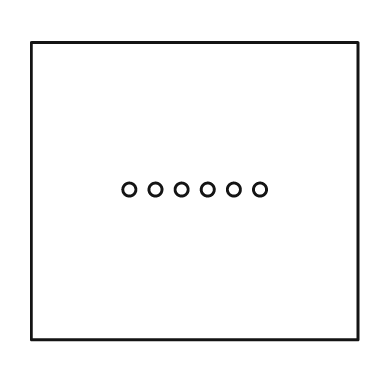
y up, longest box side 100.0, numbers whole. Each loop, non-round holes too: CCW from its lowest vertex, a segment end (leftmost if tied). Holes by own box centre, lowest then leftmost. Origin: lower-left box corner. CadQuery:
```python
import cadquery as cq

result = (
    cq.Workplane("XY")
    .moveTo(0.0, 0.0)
    .lineTo(100.0, 0.0)
    .lineTo(100.0, 91.0)
    .lineTo(0.0, 91.0)
    .close()
    .moveTo(30.0, 46.0)
    .circle(2.0)
    .moveTo(38.0, 46.0)
    .circle(2.0)
    .moveTo(46.0, 46.0)
    .circle(2.0)
    .moveTo(54.0, 46.0)
    .circle(2.0)
    .moveTo(62.0, 46.0)
    .circle(2.0)
    .moveTo(70.0, 46.0)
    .circle(2.0)
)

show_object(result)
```